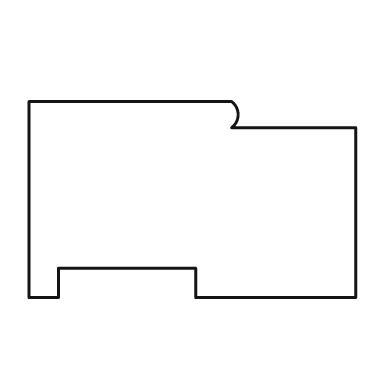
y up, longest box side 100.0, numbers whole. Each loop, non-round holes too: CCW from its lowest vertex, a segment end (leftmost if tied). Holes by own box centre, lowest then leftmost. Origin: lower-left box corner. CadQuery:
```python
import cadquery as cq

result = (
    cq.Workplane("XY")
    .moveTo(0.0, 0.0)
    .lineTo(9.0, 0.0)
    .lineTo(9.0, 9.0)
    .lineTo(51.0, 9.0)
    .lineTo(51.0, 0.0)
    .lineTo(100.0, 0.0)
    .lineTo(100.0, 52.0)
    .lineTo(62.0, 52.0)
    .threePointArc((64.0, 56.0), (62.0, 60.0))
    .lineTo(0.0, 60.0)
    .close()
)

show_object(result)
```